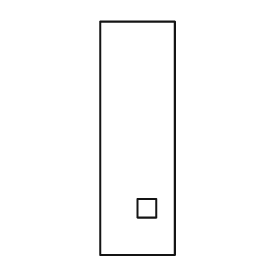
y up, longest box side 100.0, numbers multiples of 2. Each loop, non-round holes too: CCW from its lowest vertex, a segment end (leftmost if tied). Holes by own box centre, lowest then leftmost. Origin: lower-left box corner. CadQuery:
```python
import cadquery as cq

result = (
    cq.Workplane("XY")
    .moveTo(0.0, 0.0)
    .lineTo(32.0, 0.0)
    .lineTo(32.0, 100.0)
    .lineTo(0.0, 100.0)
    .close()
    .moveTo(16.0, 16.0)
    .lineTo(24.0, 16.0)
    .lineTo(24.0, 24.0)
    .lineTo(16.0, 24.0)
    .close()
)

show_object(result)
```